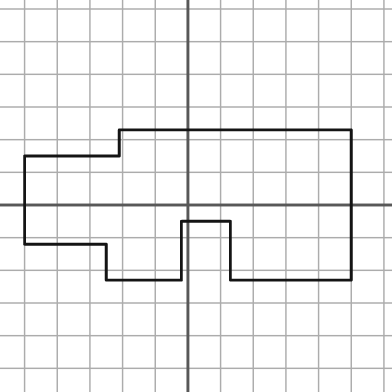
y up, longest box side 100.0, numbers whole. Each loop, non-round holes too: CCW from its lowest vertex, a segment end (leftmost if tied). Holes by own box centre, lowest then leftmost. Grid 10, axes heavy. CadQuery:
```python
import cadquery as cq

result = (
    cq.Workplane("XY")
    .moveTo(-25.0, -23.0)
    .lineTo(-2.0, -23.0)
    .lineTo(-2.0, -5.0)
    .lineTo(13.0, -5.0)
    .lineTo(13.0, -23.0)
    .lineTo(50.0, -23.0)
    .lineTo(50.0, 23.0)
    .lineTo(-21.0, 23.0)
    .lineTo(-21.0, 15.0)
    .lineTo(-50.0, 15.0)
    .lineTo(-50.0, -12.0)
    .lineTo(-25.0, -12.0)
    .close()
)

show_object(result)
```